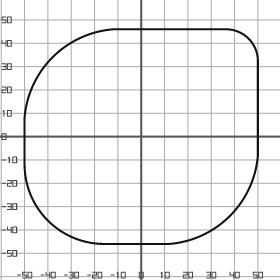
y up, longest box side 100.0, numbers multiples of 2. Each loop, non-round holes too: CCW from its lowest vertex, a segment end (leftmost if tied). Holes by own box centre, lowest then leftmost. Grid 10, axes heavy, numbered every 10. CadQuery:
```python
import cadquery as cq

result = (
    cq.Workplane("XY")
    .moveTo(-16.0, -46.0)
    .lineTo(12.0, -46.0)
    .threePointArc((38.0, -34.0), (50.0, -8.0))
    .lineTo(50.0, 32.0)
    .threePointArc((46.0, 42.0), (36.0, 46.0))
    .lineTo(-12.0, 46.0)
    .threePointArc((-38.0, 34.0), (-50.0, 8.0))
    .lineTo(-50.0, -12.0)
    .threePointArc((-40.0, -36.0), (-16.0, -46.0))
    .close()
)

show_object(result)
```